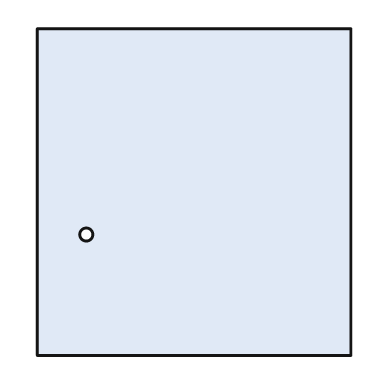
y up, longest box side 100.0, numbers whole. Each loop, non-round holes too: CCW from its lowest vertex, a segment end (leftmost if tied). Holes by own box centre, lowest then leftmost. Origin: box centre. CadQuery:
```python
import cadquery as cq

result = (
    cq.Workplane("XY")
    .moveTo(-48.0, -50.0)
    .lineTo(48.0, -50.0)
    .lineTo(48.0, 50.0)
    .lineTo(-48.0, 50.0)
    .close()
    .moveTo(-33.0, -13.0)
    .circle(2.0)
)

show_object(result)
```